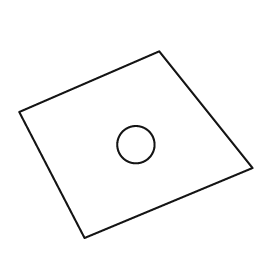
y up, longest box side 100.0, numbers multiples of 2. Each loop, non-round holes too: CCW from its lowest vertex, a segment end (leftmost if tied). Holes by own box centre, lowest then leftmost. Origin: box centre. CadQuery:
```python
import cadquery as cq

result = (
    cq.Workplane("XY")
    .moveTo(-22.0, -40.0)
    .lineTo(50.0, -10.0)
    .lineTo(10.0, 40.0)
    .lineTo(-50.0, 14.0)
    .close()
    .moveTo(0.0, 0.0)
    .circle(8.0)
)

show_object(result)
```